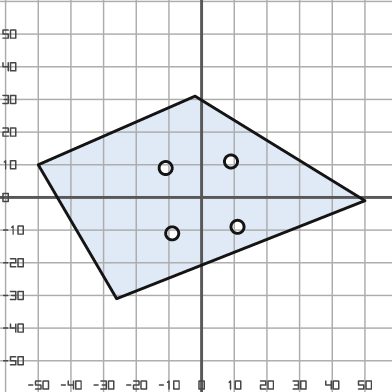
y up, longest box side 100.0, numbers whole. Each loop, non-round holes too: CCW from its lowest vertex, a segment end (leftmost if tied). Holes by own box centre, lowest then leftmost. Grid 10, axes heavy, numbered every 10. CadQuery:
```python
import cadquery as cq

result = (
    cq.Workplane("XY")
    .moveTo(-26.0, -31.0)
    .lineTo(50.0, -1.0)
    .lineTo(-2.0, 31.0)
    .lineTo(-50.0, 10.0)
    .close()
    .moveTo(-9.0, -11.0)
    .circle(2.0)
    .moveTo(11.0, -9.0)
    .circle(2.0)
    .moveTo(-11.0, 9.0)
    .circle(2.0)
    .moveTo(9.0, 11.0)
    .circle(2.0)
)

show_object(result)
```